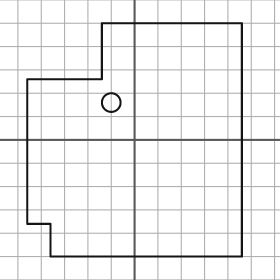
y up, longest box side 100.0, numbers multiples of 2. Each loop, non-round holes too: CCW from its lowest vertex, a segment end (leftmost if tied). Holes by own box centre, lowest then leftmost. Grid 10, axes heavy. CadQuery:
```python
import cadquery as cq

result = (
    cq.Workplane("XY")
    .moveTo(-36.0, -50.0)
    .lineTo(46.0, -50.0)
    .lineTo(46.0, 50.0)
    .lineTo(-14.0, 50.0)
    .lineTo(-14.0, 26.0)
    .lineTo(-46.0, 26.0)
    .lineTo(-46.0, -36.0)
    .lineTo(-36.0, -36.0)
    .close()
    .moveTo(-10.0, 16.0)
    .circle(4.0)
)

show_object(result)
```